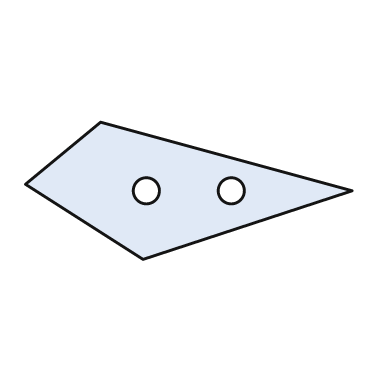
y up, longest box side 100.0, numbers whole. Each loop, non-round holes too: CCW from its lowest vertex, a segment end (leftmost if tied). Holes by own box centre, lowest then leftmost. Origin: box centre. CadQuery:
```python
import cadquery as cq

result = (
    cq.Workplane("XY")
    .moveTo(-14.0, -21.0)
    .lineTo(50.0, 0.0)
    .lineTo(-27.0, 21.0)
    .lineTo(-50.0, 2.0)
    .close()
    .moveTo(-13.0, 0.0)
    .circle(4.0)
    .moveTo(13.0, 0.0)
    .circle(4.0)
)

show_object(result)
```